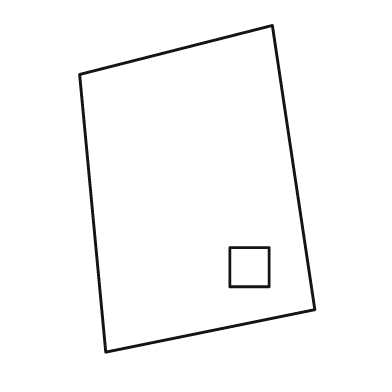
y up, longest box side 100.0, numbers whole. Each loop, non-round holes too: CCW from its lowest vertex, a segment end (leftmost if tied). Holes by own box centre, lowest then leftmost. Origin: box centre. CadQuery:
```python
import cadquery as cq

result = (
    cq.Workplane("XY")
    .moveTo(-28.0, -50.0)
    .lineTo(36.0, -37.0)
    .lineTo(23.0, 50.0)
    .lineTo(-36.0, 35.0)
    .close()
    .moveTo(10.0, -30.0)
    .lineTo(22.0, -30.0)
    .lineTo(22.0, -18.0)
    .lineTo(10.0, -18.0)
    .close()
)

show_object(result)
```